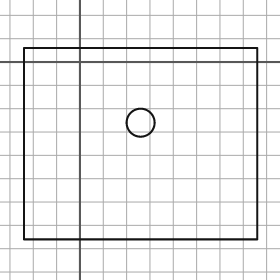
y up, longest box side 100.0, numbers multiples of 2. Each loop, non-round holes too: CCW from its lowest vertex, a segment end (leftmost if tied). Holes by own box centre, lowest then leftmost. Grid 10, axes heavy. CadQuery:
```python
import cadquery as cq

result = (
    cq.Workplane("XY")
    .moveTo(-24.0, -76.0)
    .lineTo(76.0, -76.0)
    .lineTo(76.0, 6.0)
    .lineTo(-24.0, 6.0)
    .close()
    .moveTo(26.0, -26.0)
    .circle(6.0)
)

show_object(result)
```